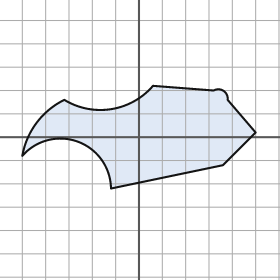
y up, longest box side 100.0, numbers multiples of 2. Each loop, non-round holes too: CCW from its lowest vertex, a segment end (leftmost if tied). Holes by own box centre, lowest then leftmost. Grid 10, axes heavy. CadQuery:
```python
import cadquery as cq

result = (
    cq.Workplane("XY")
    .moveTo(-12.0, -22.0)
    .lineTo(36.0, -12.0)
    .lineTo(50.0, 2.0)
    .lineTo(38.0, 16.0)
    .threePointArc((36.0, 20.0), (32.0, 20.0))
    .lineTo(6.0, 22.0)
    .threePointArc((-12.0, 12.0), (-32.0, 16.0))
    .threePointArc((-44.0, 6.0), (-50.0, -8.0))
    .threePointArc((-26.0, -2.0), (-12.0, -22.0))
    .close()
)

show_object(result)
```